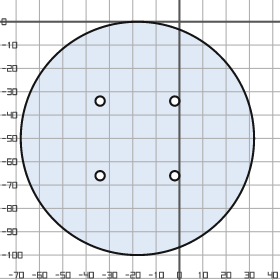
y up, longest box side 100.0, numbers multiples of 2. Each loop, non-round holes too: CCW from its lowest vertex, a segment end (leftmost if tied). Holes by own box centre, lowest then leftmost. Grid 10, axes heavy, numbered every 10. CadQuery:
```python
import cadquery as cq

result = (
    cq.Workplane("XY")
    .moveTo(-18.0, -50.0)
    .circle(50.0)
    .moveTo(-34.0, -66.0)
    .circle(2.0)
    .moveTo(-2.0, -66.0)
    .circle(2.0)
    .moveTo(-34.0, -34.0)
    .circle(2.0)
    .moveTo(-2.0, -34.0)
    .circle(2.0)
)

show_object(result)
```